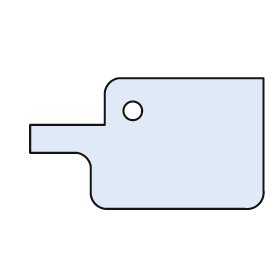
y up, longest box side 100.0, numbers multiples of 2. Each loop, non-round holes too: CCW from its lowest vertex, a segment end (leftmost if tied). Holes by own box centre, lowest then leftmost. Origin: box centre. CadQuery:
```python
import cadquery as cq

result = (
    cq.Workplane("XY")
    .moveTo(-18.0, -28.0)
    .lineTo(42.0, -28.0)
    .threePointArc((48.0, -26.0), (50.0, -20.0))
    .lineTo(50.0, 28.0)
    .lineTo(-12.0, 28.0)
    .threePointArc((-16.0, 26.0), (-18.0, 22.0))
    .lineTo(-18.0, 8.0)
    .lineTo(-50.0, 8.0)
    .lineTo(-50.0, -4.0)
    .lineTo(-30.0, -4.0)
    .threePointArc((-26.0, -6.0), (-24.0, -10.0))
    .lineTo(-24.0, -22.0)
    .threePointArc((-22.0, -26.0), (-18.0, -28.0))
    .close()
    .moveTo(-6.0, 14.0)
    .circle(4.0)
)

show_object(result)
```